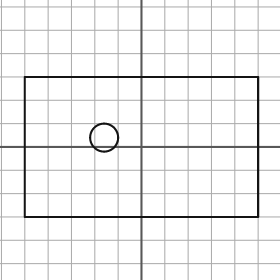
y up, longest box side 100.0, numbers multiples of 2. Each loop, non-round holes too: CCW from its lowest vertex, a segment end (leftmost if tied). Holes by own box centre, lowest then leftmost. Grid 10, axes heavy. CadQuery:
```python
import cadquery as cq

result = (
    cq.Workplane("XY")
    .moveTo(-50.0, -30.0)
    .lineTo(50.0, -30.0)
    .lineTo(50.0, 30.0)
    .lineTo(-50.0, 30.0)
    .close()
    .moveTo(-16.0, 4.0)
    .circle(6.0)
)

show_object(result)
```